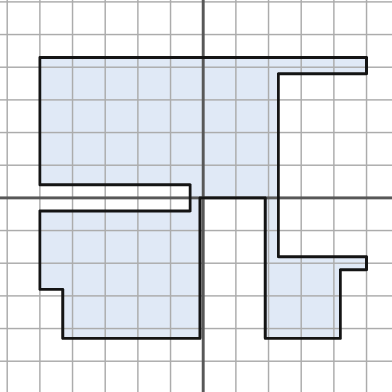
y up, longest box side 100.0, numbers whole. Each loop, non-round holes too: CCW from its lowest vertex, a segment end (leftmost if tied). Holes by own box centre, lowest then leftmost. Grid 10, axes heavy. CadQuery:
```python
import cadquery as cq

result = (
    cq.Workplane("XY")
    .moveTo(-43.0, -43.0)
    .lineTo(-1.0, -43.0)
    .lineTo(-1.0, 0.0)
    .lineTo(19.0, 0.0)
    .lineTo(19.0, -43.0)
    .lineTo(42.0, -43.0)
    .lineTo(42.0, -22.0)
    .lineTo(50.0, -22.0)
    .lineTo(50.0, -18.0)
    .lineTo(23.0, -18.0)
    .lineTo(23.0, 38.0)
    .lineTo(50.0, 38.0)
    .lineTo(50.0, 43.0)
    .lineTo(-50.0, 43.0)
    .lineTo(-50.0, 4.0)
    .lineTo(-4.0, 4.0)
    .lineTo(-4.0, -4.0)
    .lineTo(-50.0, -4.0)
    .lineTo(-50.0, -28.0)
    .lineTo(-43.0, -28.0)
    .close()
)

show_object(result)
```